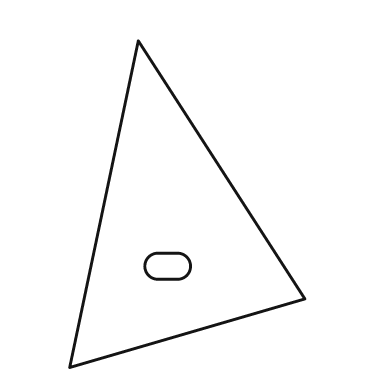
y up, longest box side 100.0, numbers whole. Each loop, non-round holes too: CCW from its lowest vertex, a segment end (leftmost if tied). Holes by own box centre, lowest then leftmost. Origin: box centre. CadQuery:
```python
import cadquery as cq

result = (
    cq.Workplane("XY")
    .moveTo(-36.0, -50.0)
    .lineTo(36.0, -29.0)
    .lineTo(-15.0, 50.0)
    .close()
    .moveTo(-9.0, -23.0)
    .lineTo(-3.0, -23.0)
    .threePointArc((1.0, -19.0), (-3.0, -15.0))
    .lineTo(-9.0, -15.0)
    .threePointArc((-13.0, -19.0), (-9.0, -23.0))
    .close()
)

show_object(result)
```